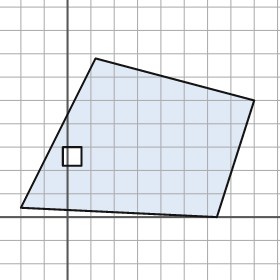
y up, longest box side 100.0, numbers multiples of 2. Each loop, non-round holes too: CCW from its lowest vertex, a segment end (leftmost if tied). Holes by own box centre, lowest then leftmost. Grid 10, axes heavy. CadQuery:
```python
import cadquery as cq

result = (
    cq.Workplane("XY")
    .moveTo(64.0, 0.0)
    .lineTo(80.0, 50.0)
    .lineTo(12.0, 68.0)
    .lineTo(-20.0, 4.0)
    .close()
    .moveTo(-2.0, 22.0)
    .lineTo(6.0, 22.0)
    .lineTo(6.0, 30.0)
    .lineTo(-2.0, 30.0)
    .close()
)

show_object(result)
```